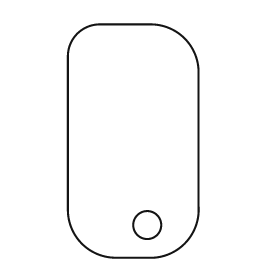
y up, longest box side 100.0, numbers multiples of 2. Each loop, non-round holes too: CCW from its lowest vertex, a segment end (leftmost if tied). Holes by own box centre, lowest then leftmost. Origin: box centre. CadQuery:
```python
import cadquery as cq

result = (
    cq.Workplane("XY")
    .moveTo(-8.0, -50.0)
    .lineTo(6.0, -50.0)
    .threePointArc((22.0, -44.0), (28.0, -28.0))
    .lineTo(28.0, 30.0)
    .threePointArc((22.0, 44.0), (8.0, 50.0))
    .lineTo(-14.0, 50.0)
    .threePointArc((-24.0, 46.0), (-28.0, 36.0))
    .lineTo(-28.0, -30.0)
    .threePointArc((-22.0, -44.0), (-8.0, -50.0))
    .close()
    .moveTo(6.0, -36.0)
    .circle(6.0)
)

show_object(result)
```